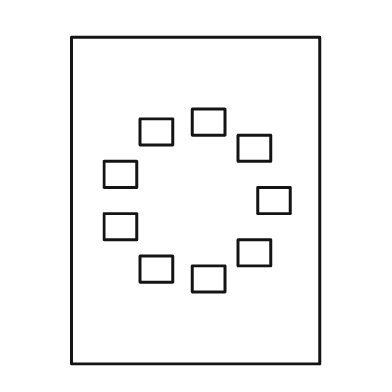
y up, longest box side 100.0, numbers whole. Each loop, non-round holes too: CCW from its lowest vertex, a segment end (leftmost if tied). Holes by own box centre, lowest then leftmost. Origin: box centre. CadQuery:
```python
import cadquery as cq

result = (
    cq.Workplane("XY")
    .moveTo(-38.0, -50.0)
    .lineTo(38.0, -50.0)
    .lineTo(38.0, 50.0)
    .lineTo(-38.0, 50.0)
    .close()
    .moveTo(-1.0, -28.0)
    .lineTo(9.0, -28.0)
    .lineTo(9.0, -20.0)
    .lineTo(-1.0, -20.0)
    .close()
    .moveTo(-17.0, -25.0)
    .lineTo(-7.0, -25.0)
    .lineTo(-7.0, -17.0)
    .lineTo(-17.0, -17.0)
    .close()
    .moveTo(13.0, -20.0)
    .lineTo(23.0, -20.0)
    .lineTo(23.0, -12.0)
    .lineTo(13.0, -12.0)
    .close()
    .moveTo(-28.0, -12.0)
    .lineTo(-18.0, -12.0)
    .lineTo(-18.0, -4.0)
    .lineTo(-28.0, -4.0)
    .close()
    .moveTo(19.0, -4.0)
    .lineTo(29.0, -4.0)
    .lineTo(29.0, 4.0)
    .lineTo(19.0, 4.0)
    .close()
    .moveTo(-28.0, 4.0)
    .lineTo(-18.0, 4.0)
    .lineTo(-18.0, 12.0)
    .lineTo(-28.0, 12.0)
    .close()
    .moveTo(13.0, 12.0)
    .lineTo(23.0, 12.0)
    .lineTo(23.0, 20.0)
    .lineTo(13.0, 20.0)
    .close()
    .moveTo(-17.0, 17.0)
    .lineTo(-7.0, 17.0)
    .lineTo(-7.0, 25.0)
    .lineTo(-17.0, 25.0)
    .close()
    .moveTo(-1.0, 20.0)
    .lineTo(9.0, 20.0)
    .lineTo(9.0, 28.0)
    .lineTo(-1.0, 28.0)
    .close()
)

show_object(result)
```